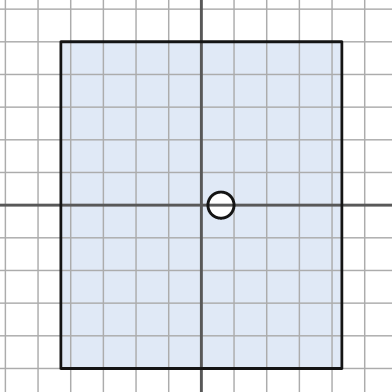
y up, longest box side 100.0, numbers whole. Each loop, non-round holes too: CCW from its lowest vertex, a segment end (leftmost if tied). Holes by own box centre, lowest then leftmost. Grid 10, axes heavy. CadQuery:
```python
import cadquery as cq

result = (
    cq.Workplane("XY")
    .moveTo(-43.0, -50.0)
    .lineTo(43.0, -50.0)
    .lineTo(43.0, 50.0)
    .lineTo(-43.0, 50.0)
    .close()
    .moveTo(6.0, 0.0)
    .circle(4.0)
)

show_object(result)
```